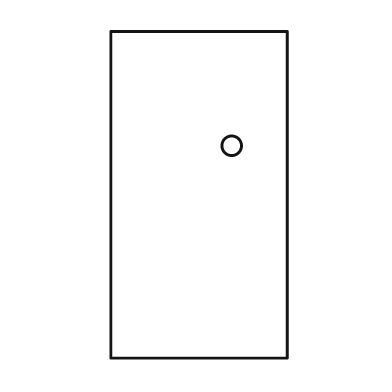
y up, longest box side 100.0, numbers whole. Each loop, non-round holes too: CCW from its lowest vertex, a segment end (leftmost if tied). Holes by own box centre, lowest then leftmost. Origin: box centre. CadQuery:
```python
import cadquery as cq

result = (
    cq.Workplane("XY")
    .moveTo(-27.0, -50.0)
    .lineTo(27.0, -50.0)
    .lineTo(27.0, 50.0)
    .lineTo(-27.0, 50.0)
    .close()
    .moveTo(10.0, 15.0)
    .circle(3.0)
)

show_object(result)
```